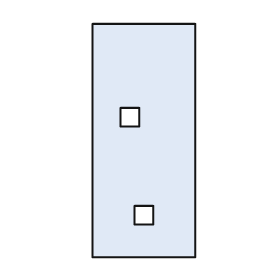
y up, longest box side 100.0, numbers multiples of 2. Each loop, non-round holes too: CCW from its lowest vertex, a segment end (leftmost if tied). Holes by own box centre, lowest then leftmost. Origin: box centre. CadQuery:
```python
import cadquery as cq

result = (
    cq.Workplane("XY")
    .moveTo(-22.0, -50.0)
    .lineTo(22.0, -50.0)
    .lineTo(22.0, 50.0)
    .lineTo(-22.0, 50.0)
    .close()
    .moveTo(-4.0, -36.0)
    .lineTo(4.0, -36.0)
    .lineTo(4.0, -28.0)
    .lineTo(-4.0, -28.0)
    .close()
    .moveTo(-10.0, 6.0)
    .lineTo(-2.0, 6.0)
    .lineTo(-2.0, 14.0)
    .lineTo(-10.0, 14.0)
    .close()
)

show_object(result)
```